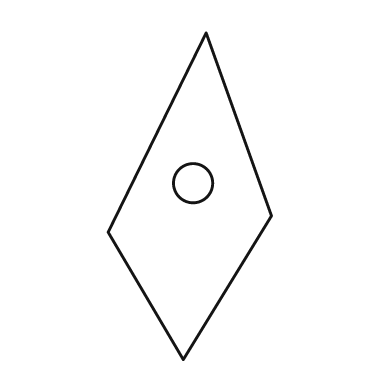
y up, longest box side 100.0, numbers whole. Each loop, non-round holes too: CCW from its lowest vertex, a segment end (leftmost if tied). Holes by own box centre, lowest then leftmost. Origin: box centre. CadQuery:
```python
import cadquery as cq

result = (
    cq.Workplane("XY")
    .moveTo(-2.0, -50.0)
    .lineTo(25.0, -6.0)
    .lineTo(5.0, 50.0)
    .lineTo(-25.0, -11.0)
    .close()
    .moveTo(1.0, 4.0)
    .circle(6.0)
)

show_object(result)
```